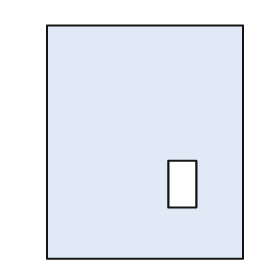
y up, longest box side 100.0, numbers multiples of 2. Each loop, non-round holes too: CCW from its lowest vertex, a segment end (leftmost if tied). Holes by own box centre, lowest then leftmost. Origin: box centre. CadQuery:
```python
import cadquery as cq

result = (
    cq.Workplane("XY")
    .moveTo(-42.0, -50.0)
    .lineTo(42.0, -50.0)
    .lineTo(42.0, 50.0)
    .lineTo(-42.0, 50.0)
    .close()
    .moveTo(10.0, -28.0)
    .lineTo(22.0, -28.0)
    .lineTo(22.0, -8.0)
    .lineTo(10.0, -8.0)
    .close()
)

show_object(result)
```